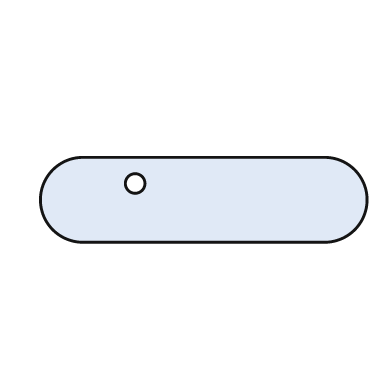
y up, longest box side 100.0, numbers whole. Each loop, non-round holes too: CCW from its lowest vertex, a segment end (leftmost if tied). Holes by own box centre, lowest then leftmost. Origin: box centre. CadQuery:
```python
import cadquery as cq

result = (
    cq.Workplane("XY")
    .moveTo(-37.0, -13.0)
    .lineTo(37.0, -13.0)
    .threePointArc((50.0, 0.0), (37.0, 13.0))
    .lineTo(-37.0, 13.0)
    .threePointArc((-50.0, 0.0), (-37.0, -13.0))
    .close()
    .moveTo(-21.0, 5.0)
    .circle(3.0)
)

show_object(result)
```